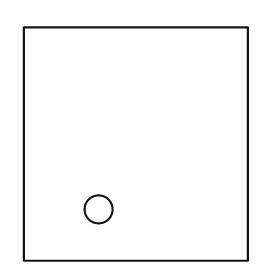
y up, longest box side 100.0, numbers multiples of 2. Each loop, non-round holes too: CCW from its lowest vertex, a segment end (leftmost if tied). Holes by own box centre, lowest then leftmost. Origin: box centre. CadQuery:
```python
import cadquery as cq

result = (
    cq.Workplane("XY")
    .moveTo(-48.0, -50.0)
    .lineTo(48.0, -50.0)
    .lineTo(48.0, 50.0)
    .lineTo(-48.0, 50.0)
    .close()
    .moveTo(-16.0, -28.0)
    .circle(6.0)
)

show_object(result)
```